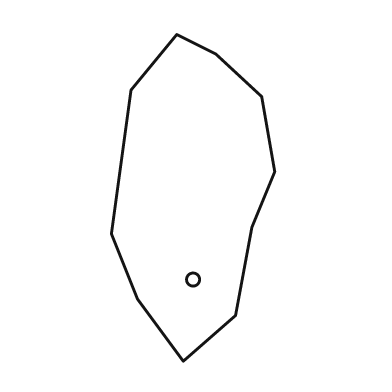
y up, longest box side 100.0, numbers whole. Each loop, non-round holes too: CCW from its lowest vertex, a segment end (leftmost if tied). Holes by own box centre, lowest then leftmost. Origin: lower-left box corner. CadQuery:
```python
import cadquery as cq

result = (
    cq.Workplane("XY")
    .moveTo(22.0, 0.0)
    .lineTo(38.0, 14.0)
    .lineTo(43.0, 41.0)
    .lineTo(50.0, 58.0)
    .lineTo(46.0, 81.0)
    .lineTo(32.0, 94.0)
    .lineTo(20.0, 100.0)
    .lineTo(6.0, 83.0)
    .lineTo(0.0, 39.0)
    .lineTo(8.0, 19.0)
    .close()
    .moveTo(25.0, 25.0)
    .circle(2.0)
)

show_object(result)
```